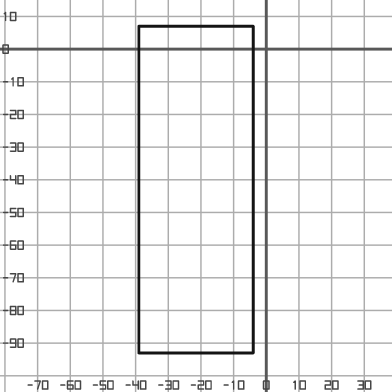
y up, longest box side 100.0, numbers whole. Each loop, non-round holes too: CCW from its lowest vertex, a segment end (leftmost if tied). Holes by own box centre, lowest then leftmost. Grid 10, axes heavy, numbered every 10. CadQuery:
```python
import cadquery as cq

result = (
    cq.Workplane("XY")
    .moveTo(-39.0, -93.0)
    .lineTo(-4.0, -93.0)
    .lineTo(-4.0, 7.0)
    .lineTo(-39.0, 7.0)
    .close()
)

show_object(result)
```